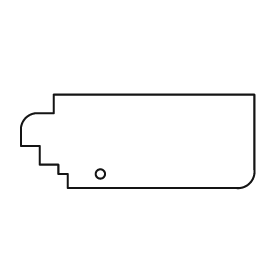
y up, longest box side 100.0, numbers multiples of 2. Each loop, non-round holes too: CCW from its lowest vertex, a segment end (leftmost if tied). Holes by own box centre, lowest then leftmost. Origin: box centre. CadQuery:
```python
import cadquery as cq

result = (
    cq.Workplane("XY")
    .moveTo(-30.0, -20.0)
    .lineTo(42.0, -20.0)
    .threePointArc((48.0, -18.0), (50.0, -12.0))
    .lineTo(50.0, 20.0)
    .lineTo(-36.0, 20.0)
    .lineTo(-36.0, 12.0)
    .lineTo(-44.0, 12.0)
    .threePointArc((-48.0, 10.0), (-50.0, 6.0))
    .lineTo(-50.0, -2.0)
    .lineTo(-42.0, -2.0)
    .lineTo(-42.0, -10.0)
    .lineTo(-34.0, -10.0)
    .lineTo(-34.0, -14.0)
    .lineTo(-30.0, -14.0)
    .close()
    .moveTo(-16.0, -14.0)
    .circle(2.0)
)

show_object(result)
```